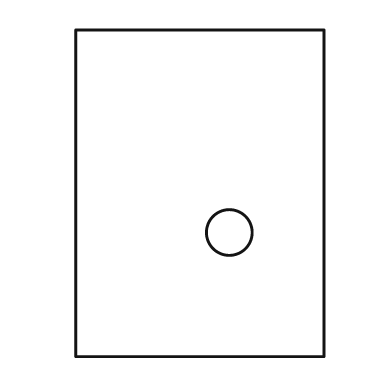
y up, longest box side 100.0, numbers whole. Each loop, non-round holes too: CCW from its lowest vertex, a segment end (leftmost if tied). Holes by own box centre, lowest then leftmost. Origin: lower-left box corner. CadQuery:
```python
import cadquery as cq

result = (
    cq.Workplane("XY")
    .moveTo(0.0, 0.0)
    .lineTo(76.0, 0.0)
    .lineTo(76.0, 100.0)
    .lineTo(0.0, 100.0)
    .close()
    .moveTo(47.0, 38.0)
    .circle(7.0)
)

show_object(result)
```